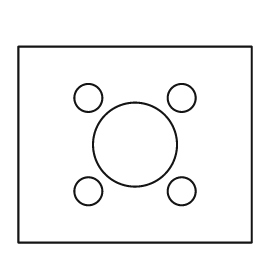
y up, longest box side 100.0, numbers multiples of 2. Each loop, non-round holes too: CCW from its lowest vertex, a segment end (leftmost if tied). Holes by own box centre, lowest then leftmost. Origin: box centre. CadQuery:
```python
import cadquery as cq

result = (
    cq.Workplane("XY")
    .moveTo(-50.0, -42.0)
    .lineTo(50.0, -42.0)
    .lineTo(50.0, 42.0)
    .lineTo(-50.0, 42.0)
    .close()
    .moveTo(-20.0, -20.0)
    .circle(6.0)
    .moveTo(20.0, -20.0)
    .circle(6.0)
    .moveTo(0.0, 0.0)
    .circle(18.0)
    .moveTo(-20.0, 20.0)
    .circle(6.0)
    .moveTo(20.0, 20.0)
    .circle(6.0)
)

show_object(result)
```